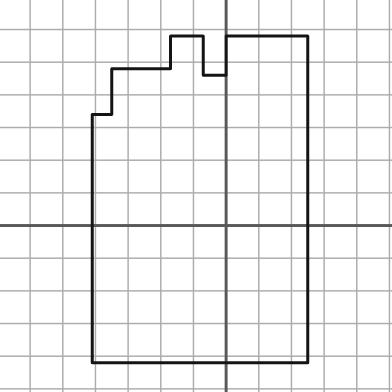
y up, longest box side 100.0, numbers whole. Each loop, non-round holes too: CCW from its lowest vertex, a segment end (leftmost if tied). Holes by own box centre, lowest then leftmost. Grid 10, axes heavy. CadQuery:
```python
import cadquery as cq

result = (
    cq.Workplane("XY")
    .moveTo(-41.0, -42.0)
    .lineTo(25.0, -42.0)
    .lineTo(25.0, 58.0)
    .lineTo(0.0, 58.0)
    .lineTo(0.0, 46.0)
    .lineTo(-7.0, 46.0)
    .lineTo(-7.0, 58.0)
    .lineTo(-17.0, 58.0)
    .lineTo(-17.0, 48.0)
    .lineTo(-35.0, 48.0)
    .lineTo(-35.0, 34.0)
    .lineTo(-41.0, 34.0)
    .close()
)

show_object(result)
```